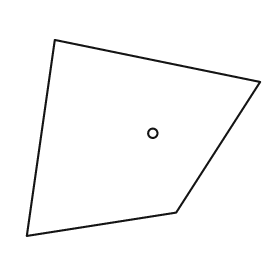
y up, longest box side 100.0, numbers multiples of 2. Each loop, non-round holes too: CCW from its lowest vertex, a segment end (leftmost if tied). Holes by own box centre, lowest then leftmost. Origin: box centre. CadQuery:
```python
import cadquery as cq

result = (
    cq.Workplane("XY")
    .moveTo(-50.0, -42.0)
    .lineTo(14.0, -32.0)
    .lineTo(50.0, 24.0)
    .lineTo(-38.0, 42.0)
    .close()
    .moveTo(4.0, 2.0)
    .circle(2.0)
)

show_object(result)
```